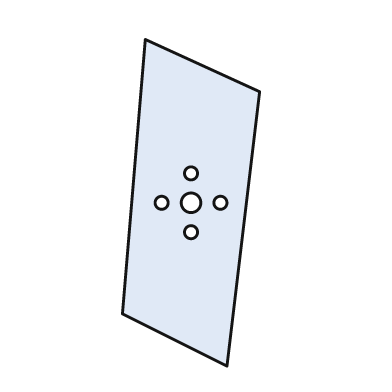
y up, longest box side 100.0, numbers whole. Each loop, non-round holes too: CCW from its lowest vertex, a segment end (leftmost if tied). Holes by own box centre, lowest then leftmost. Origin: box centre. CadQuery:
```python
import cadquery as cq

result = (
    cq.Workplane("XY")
    .moveTo(11.0, -50.0)
    .lineTo(21.0, 34.0)
    .lineTo(-14.0, 50.0)
    .lineTo(-21.0, -34.0)
    .close()
    .moveTo(0.0, -9.0)
    .circle(2.0)
    .moveTo(-9.0, 0.0)
    .circle(2.0)
    .moveTo(0.0, 0.0)
    .circle(3.0)
    .moveTo(9.0, 0.0)
    .circle(2.0)
    .moveTo(0.0, 9.0)
    .circle(2.0)
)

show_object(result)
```